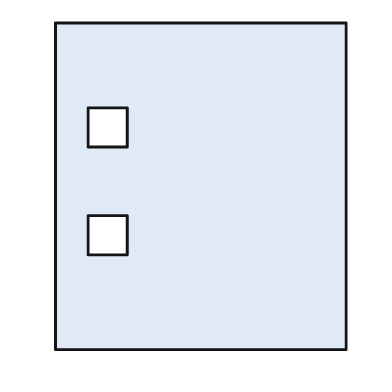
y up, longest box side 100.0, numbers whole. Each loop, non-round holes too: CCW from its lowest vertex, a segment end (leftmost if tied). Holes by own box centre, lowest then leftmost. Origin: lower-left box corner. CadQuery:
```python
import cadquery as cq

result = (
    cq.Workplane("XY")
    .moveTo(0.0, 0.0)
    .lineTo(89.0, 0.0)
    .lineTo(89.0, 100.0)
    .lineTo(0.0, 100.0)
    .close()
    .moveTo(10.0, 29.0)
    .lineTo(22.0, 29.0)
    .lineTo(22.0, 41.0)
    .lineTo(10.0, 41.0)
    .close()
    .moveTo(10.0, 62.0)
    .lineTo(22.0, 62.0)
    .lineTo(22.0, 74.0)
    .lineTo(10.0, 74.0)
    .close()
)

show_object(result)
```